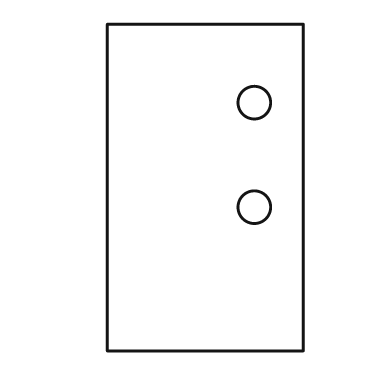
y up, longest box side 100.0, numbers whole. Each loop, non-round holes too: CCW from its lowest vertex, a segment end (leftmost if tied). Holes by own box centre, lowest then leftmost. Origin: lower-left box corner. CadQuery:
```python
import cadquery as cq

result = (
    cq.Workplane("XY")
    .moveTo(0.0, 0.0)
    .lineTo(60.0, 0.0)
    .lineTo(60.0, 100.0)
    .lineTo(0.0, 100.0)
    .close()
    .moveTo(45.0, 44.0)
    .circle(5.0)
    .moveTo(45.0, 76.0)
    .circle(5.0)
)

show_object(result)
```